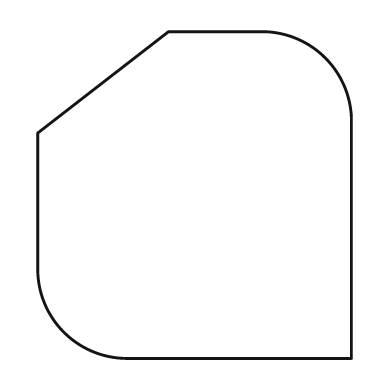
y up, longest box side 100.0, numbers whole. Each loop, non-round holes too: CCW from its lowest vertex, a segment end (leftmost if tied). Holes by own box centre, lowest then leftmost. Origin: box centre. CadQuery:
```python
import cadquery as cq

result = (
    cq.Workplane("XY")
    .moveTo(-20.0, -50.0)
    .lineTo(48.0, -50.0)
    .lineTo(48.0, 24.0)
    .threePointArc((40.0, 42.0), (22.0, 50.0))
    .lineTo(-8.0, 50.0)
    .lineTo(-48.0, 19.0)
    .lineTo(-48.0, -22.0)
    .threePointArc((-40.0, -42.0), (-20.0, -50.0))
    .close()
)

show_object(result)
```